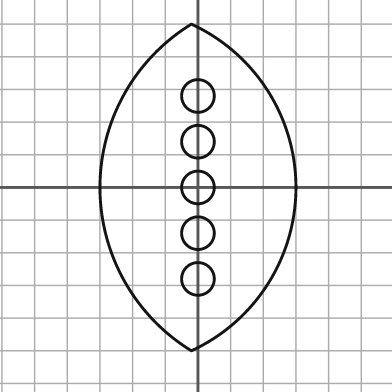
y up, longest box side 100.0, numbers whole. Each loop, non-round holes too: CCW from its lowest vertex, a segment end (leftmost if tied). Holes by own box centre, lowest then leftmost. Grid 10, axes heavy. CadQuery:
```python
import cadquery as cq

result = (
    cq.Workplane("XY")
    .moveTo(-2.0, -50.0)
    .threePointArc((30.0, 0.0), (-2.0, 50.0))
    .threePointArc((-30.0, 0.0), (-2.0, -50.0))
    .close()
    .moveTo(0.0, -28.0)
    .circle(5.0)
    .moveTo(0.0, -14.0)
    .circle(5.0)
    .moveTo(0.0, 0.0)
    .circle(5.0)
    .moveTo(0.0, 14.0)
    .circle(5.0)
    .moveTo(0.0, 28.0)
    .circle(5.0)
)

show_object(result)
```